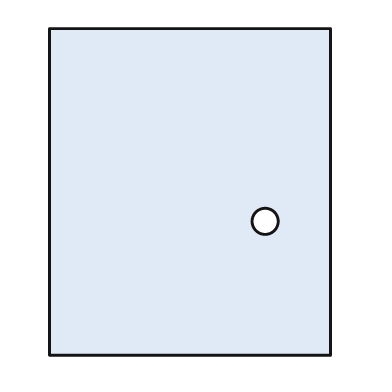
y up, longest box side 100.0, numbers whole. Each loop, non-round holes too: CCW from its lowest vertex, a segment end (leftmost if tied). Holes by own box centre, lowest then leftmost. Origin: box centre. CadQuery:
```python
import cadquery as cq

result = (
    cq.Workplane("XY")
    .moveTo(-43.0, -50.0)
    .lineTo(43.0, -50.0)
    .lineTo(43.0, 50.0)
    .lineTo(-43.0, 50.0)
    .close()
    .moveTo(23.0, -9.0)
    .circle(4.0)
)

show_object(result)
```